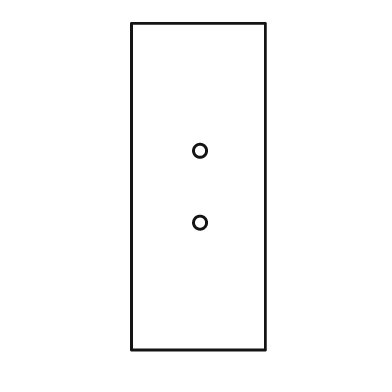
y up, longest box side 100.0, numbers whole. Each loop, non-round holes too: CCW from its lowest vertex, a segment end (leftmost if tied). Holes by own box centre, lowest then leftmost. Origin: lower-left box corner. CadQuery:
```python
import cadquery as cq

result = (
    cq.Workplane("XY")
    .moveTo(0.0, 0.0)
    .lineTo(41.0, 0.0)
    .lineTo(41.0, 100.0)
    .lineTo(0.0, 100.0)
    .close()
    .moveTo(21.0, 39.0)
    .circle(2.0)
    .moveTo(21.0, 61.0)
    .circle(2.0)
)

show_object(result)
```